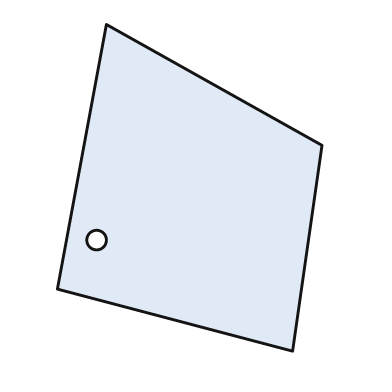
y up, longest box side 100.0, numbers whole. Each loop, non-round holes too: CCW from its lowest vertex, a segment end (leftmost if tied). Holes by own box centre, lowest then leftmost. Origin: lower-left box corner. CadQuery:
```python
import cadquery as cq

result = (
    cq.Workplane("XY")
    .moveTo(72.0, 0.0)
    .lineTo(81.0, 63.0)
    .lineTo(15.0, 100.0)
    .lineTo(0.0, 19.0)
    .close()
    .moveTo(12.0, 34.0)
    .circle(3.0)
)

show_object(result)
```